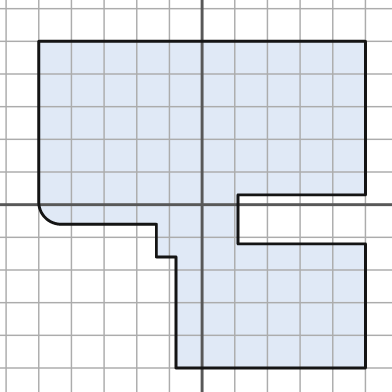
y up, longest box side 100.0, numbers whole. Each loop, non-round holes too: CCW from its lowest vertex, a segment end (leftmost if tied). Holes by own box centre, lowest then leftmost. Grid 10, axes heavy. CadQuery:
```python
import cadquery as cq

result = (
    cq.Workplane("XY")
    .moveTo(-8.0, -50.0)
    .lineTo(50.0, -50.0)
    .lineTo(50.0, -12.0)
    .lineTo(11.0, -12.0)
    .lineTo(11.0, 3.0)
    .lineTo(50.0, 3.0)
    .lineTo(50.0, 50.0)
    .lineTo(-50.0, 50.0)
    .lineTo(-50.0, 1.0)
    .threePointArc((-48.0, -4.0), (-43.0, -6.0))
    .lineTo(-14.0, -6.0)
    .lineTo(-14.0, -16.0)
    .lineTo(-8.0, -16.0)
    .close()
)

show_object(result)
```